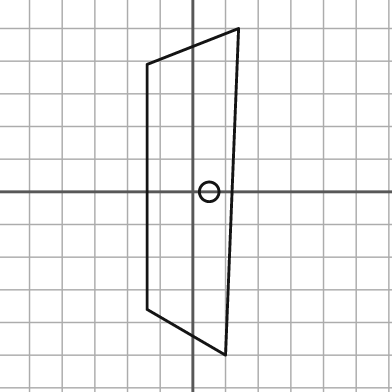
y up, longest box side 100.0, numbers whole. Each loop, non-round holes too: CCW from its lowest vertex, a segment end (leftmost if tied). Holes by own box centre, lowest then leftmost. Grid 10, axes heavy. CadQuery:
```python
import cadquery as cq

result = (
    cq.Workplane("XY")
    .moveTo(10.0, -50.0)
    .lineTo(14.0, 50.0)
    .lineTo(-14.0, 39.0)
    .lineTo(-14.0, -36.0)
    .close()
    .moveTo(5.0, 0.0)
    .circle(3.0)
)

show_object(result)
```